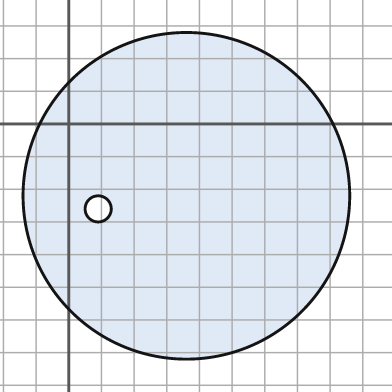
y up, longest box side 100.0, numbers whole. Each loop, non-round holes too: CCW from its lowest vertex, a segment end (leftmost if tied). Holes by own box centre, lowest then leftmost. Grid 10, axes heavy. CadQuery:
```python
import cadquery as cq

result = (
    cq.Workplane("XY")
    .moveTo(36.0, -22.0)
    .circle(50.0)
    .moveTo(9.0, -26.0)
    .circle(4.0)
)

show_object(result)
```